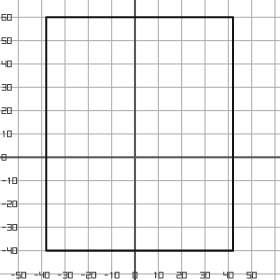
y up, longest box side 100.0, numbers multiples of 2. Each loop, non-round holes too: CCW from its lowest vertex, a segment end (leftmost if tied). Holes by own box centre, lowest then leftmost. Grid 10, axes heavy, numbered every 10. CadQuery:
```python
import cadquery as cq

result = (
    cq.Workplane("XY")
    .moveTo(-38.0, -40.0)
    .lineTo(42.0, -40.0)
    .lineTo(42.0, 60.0)
    .lineTo(-38.0, 60.0)
    .close()
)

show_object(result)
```